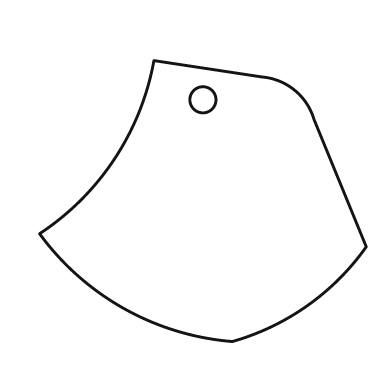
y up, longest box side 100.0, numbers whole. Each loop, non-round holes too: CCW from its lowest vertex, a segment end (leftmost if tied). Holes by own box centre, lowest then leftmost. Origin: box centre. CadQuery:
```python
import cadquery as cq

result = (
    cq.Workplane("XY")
    .moveTo(9.0, -43.0)
    .threePointArc((32.0, -32.0), (50.0, -14.0))
    .lineTo(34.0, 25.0)
    .threePointArc((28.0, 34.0), (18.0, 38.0))
    .lineTo(-15.0, 43.0)
    .threePointArc((-27.0, 13.0), (-50.0, -10.0))
    .threePointArc((-24.0, -33.0), (9.0, -43.0))
    .close()
    .moveTo(0.0, 31.0)
    .circle(4.0)
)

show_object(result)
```